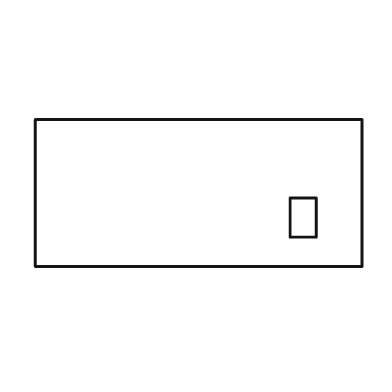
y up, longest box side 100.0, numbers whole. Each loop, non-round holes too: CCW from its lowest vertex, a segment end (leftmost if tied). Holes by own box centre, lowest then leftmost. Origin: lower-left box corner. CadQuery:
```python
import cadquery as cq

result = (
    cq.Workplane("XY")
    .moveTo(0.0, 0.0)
    .lineTo(100.0, 0.0)
    .lineTo(100.0, 45.0)
    .lineTo(0.0, 45.0)
    .close()
    .moveTo(78.0, 9.0)
    .lineTo(86.0, 9.0)
    .lineTo(86.0, 21.0)
    .lineTo(78.0, 21.0)
    .close()
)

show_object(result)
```